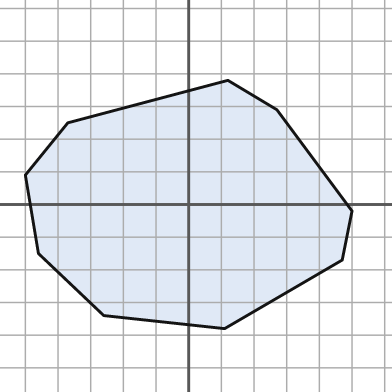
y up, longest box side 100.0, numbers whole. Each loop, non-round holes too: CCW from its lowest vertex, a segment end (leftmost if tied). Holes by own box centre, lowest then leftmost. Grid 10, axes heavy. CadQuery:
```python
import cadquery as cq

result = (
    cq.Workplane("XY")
    .moveTo(11.0, -38.0)
    .lineTo(47.0, -17.0)
    .lineTo(50.0, -2.0)
    .lineTo(27.0, 29.0)
    .lineTo(12.0, 38.0)
    .lineTo(-37.0, 25.0)
    .lineTo(-50.0, 9.0)
    .lineTo(-46.0, -15.0)
    .lineTo(-26.0, -34.0)
    .close()
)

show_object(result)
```